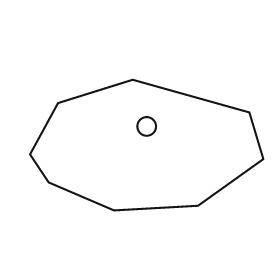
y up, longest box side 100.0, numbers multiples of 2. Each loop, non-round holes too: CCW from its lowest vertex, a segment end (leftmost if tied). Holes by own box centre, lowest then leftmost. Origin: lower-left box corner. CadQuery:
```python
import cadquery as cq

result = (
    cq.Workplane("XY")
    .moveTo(36.0, 0.0)
    .lineTo(72.0, 2.0)
    .lineTo(100.0, 22.0)
    .lineTo(94.0, 42.0)
    .lineTo(44.0, 56.0)
    .lineTo(12.0, 46.0)
    .lineTo(0.0, 24.0)
    .lineTo(8.0, 12.0)
    .close()
    .moveTo(50.0, 36.0)
    .circle(4.0)
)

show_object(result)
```